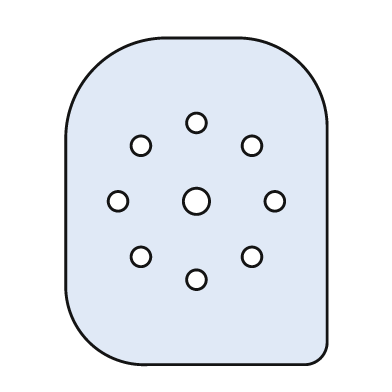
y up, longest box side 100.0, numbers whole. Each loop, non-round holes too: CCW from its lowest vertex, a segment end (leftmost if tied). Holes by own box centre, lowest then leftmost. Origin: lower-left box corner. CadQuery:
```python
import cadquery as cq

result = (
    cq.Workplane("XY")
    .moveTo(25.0, 0.0)
    .lineTo(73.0, 0.0)
    .threePointArc((78.0, 2.0), (80.0, 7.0))
    .lineTo(80.0, 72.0)
    .threePointArc((72.0, 92.0), (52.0, 100.0))
    .lineTo(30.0, 100.0)
    .threePointArc((9.0, 91.0), (0.0, 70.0))
    .lineTo(0.0, 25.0)
    .threePointArc((7.0, 7.0), (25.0, 0.0))
    .close()
    .moveTo(40.0, 26.0)
    .circle(3.0)
    .moveTo(23.0, 33.0)
    .circle(3.0)
    .moveTo(57.0, 33.0)
    .circle(3.0)
    .moveTo(16.0, 50.0)
    .circle(3.0)
    .moveTo(40.0, 50.0)
    .circle(4.0)
    .moveTo(64.0, 50.0)
    .circle(3.0)
    .moveTo(23.0, 67.0)
    .circle(3.0)
    .moveTo(57.0, 67.0)
    .circle(3.0)
    .moveTo(40.0, 74.0)
    .circle(3.0)
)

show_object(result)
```